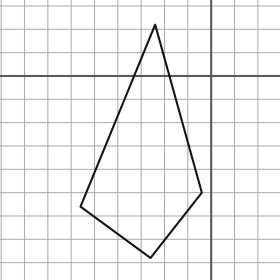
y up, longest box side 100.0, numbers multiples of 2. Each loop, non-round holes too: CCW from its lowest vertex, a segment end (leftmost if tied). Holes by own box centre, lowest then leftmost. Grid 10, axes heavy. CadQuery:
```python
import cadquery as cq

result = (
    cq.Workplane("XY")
    .moveTo(-26.0, -78.0)
    .lineTo(-4.0, -50.0)
    .lineTo(-24.0, 22.0)
    .lineTo(-56.0, -56.0)
    .close()
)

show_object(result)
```